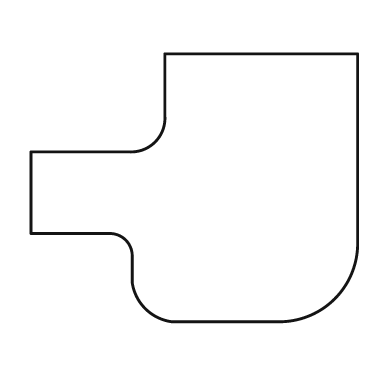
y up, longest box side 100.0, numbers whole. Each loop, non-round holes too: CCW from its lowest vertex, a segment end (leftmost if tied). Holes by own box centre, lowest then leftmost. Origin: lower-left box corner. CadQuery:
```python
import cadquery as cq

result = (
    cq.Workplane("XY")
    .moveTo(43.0, 0.0)
    .lineTo(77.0, 0.0)
    .threePointArc((93.0, 7.0), (100.0, 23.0))
    .lineTo(100.0, 82.0)
    .lineTo(41.0, 82.0)
    .lineTo(41.0, 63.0)
    .threePointArc((38.0, 55.0), (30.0, 52.0))
    .lineTo(0.0, 52.0)
    .lineTo(0.0, 27.0)
    .lineTo(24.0, 27.0)
    .threePointArc((29.0, 25.0), (31.0, 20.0))
    .lineTo(31.0, 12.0)
    .threePointArc((35.0, 4.0), (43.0, 0.0))
    .close()
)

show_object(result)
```